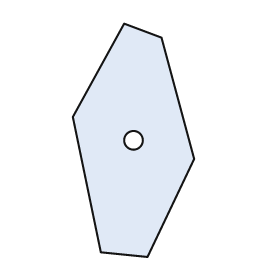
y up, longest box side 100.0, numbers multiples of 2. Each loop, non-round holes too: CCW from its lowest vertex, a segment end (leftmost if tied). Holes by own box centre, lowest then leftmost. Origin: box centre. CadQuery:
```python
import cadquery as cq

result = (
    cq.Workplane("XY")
    .moveTo(6.0, -50.0)
    .lineTo(26.0, -8.0)
    .lineTo(12.0, 44.0)
    .lineTo(-4.0, 50.0)
    .lineTo(-26.0, 10.0)
    .lineTo(-14.0, -48.0)
    .close()
    .moveTo(0.0, 0.0)
    .circle(4.0)
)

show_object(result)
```